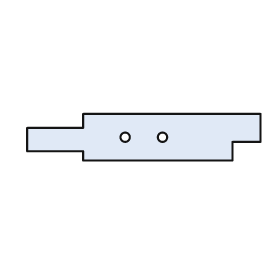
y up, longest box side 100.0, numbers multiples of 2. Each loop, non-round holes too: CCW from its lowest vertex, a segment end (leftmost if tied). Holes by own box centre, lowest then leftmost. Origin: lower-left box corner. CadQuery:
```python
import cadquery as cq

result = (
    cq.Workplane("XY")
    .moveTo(24.0, 0.0)
    .lineTo(88.0, 0.0)
    .lineTo(88.0, 8.0)
    .lineTo(100.0, 8.0)
    .lineTo(100.0, 20.0)
    .lineTo(24.0, 20.0)
    .lineTo(24.0, 14.0)
    .lineTo(0.0, 14.0)
    .lineTo(0.0, 4.0)
    .lineTo(24.0, 4.0)
    .close()
    .moveTo(42.0, 10.0)
    .circle(2.0)
    .moveTo(58.0, 10.0)
    .circle(2.0)
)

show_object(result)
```